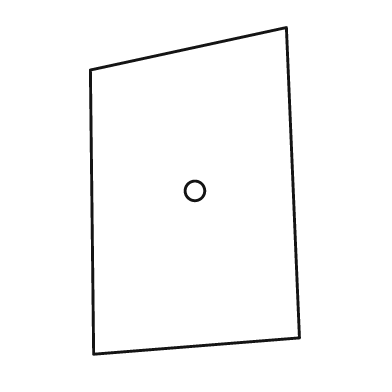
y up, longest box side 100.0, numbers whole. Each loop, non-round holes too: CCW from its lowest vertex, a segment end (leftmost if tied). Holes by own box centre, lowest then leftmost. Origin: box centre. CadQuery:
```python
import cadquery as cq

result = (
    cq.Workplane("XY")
    .moveTo(-31.0, -50.0)
    .lineTo(32.0, -45.0)
    .lineTo(28.0, 50.0)
    .lineTo(-32.0, 37.0)
    .close()
    .moveTo(0.0, 0.0)
    .circle(3.0)
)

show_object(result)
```